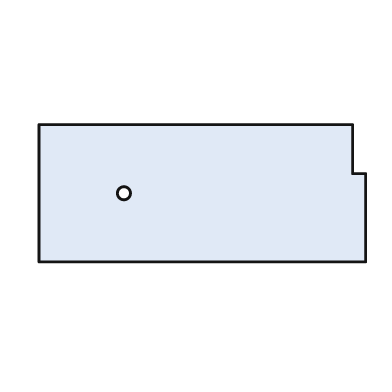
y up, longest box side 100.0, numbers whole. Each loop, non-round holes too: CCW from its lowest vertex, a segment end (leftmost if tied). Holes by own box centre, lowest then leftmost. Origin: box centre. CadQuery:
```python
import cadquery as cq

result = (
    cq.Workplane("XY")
    .moveTo(-50.0, -21.0)
    .lineTo(50.0, -21.0)
    .lineTo(50.0, 6.0)
    .lineTo(46.0, 6.0)
    .lineTo(46.0, 21.0)
    .lineTo(-50.0, 21.0)
    .close()
    .moveTo(-24.0, 0.0)
    .circle(2.0)
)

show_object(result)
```